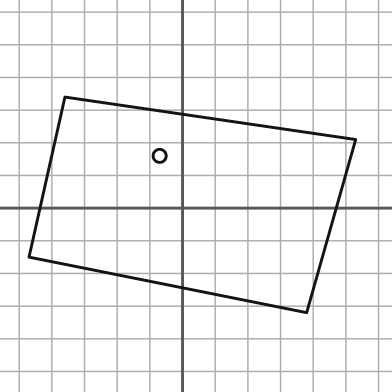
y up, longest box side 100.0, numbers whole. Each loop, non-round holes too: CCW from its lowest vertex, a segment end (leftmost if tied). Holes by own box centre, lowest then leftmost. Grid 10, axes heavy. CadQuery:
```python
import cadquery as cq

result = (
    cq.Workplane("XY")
    .moveTo(38.0, -32.0)
    .lineTo(53.0, 21.0)
    .lineTo(-36.0, 34.0)
    .lineTo(-47.0, -15.0)
    .close()
    .moveTo(-7.0, 16.0)
    .circle(2.0)
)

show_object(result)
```